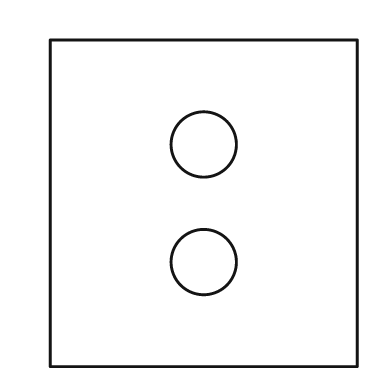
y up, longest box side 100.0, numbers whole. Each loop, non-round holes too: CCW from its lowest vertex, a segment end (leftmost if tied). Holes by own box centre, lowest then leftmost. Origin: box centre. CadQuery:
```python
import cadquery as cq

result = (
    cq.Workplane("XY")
    .moveTo(-47.0, -50.0)
    .lineTo(47.0, -50.0)
    .lineTo(47.0, 50.0)
    .lineTo(-47.0, 50.0)
    .close()
    .moveTo(0.0, -18.0)
    .circle(10.0)
    .moveTo(0.0, 18.0)
    .circle(10.0)
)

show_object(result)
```